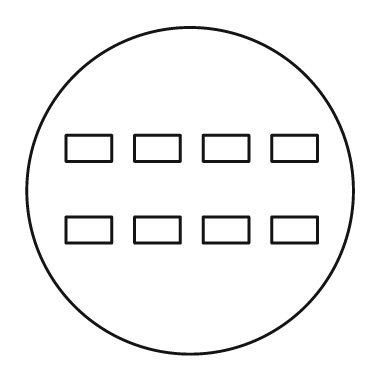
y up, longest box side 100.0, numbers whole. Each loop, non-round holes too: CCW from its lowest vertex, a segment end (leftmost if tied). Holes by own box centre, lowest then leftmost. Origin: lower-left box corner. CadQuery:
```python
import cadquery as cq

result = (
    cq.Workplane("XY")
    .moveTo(50.0, 50.0)
    .circle(50.0)
    .moveTo(12.0, 34.0)
    .lineTo(26.0, 34.0)
    .lineTo(26.0, 42.0)
    .lineTo(12.0, 42.0)
    .close()
    .moveTo(33.0, 34.0)
    .lineTo(47.0, 34.0)
    .lineTo(47.0, 42.0)
    .lineTo(33.0, 42.0)
    .close()
    .moveTo(54.0, 34.0)
    .lineTo(68.0, 34.0)
    .lineTo(68.0, 42.0)
    .lineTo(54.0, 42.0)
    .close()
    .moveTo(75.0, 34.0)
    .lineTo(89.0, 34.0)
    .lineTo(89.0, 42.0)
    .lineTo(75.0, 42.0)
    .close()
    .moveTo(12.0, 59.0)
    .lineTo(26.0, 59.0)
    .lineTo(26.0, 67.0)
    .lineTo(12.0, 67.0)
    .close()
    .moveTo(33.0, 59.0)
    .lineTo(47.0, 59.0)
    .lineTo(47.0, 67.0)
    .lineTo(33.0, 67.0)
    .close()
    .moveTo(54.0, 59.0)
    .lineTo(68.0, 59.0)
    .lineTo(68.0, 67.0)
    .lineTo(54.0, 67.0)
    .close()
    .moveTo(75.0, 59.0)
    .lineTo(89.0, 59.0)
    .lineTo(89.0, 67.0)
    .lineTo(75.0, 67.0)
    .close()
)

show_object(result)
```